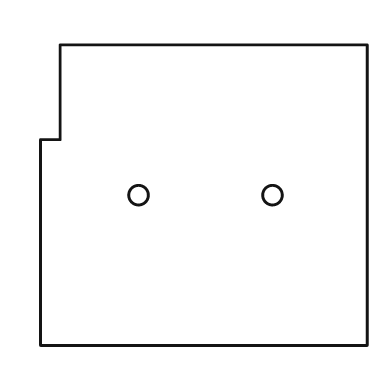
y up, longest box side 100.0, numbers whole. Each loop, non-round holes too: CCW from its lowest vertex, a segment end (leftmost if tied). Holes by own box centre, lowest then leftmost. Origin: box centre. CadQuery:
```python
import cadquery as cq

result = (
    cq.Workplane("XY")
    .moveTo(-50.0, -46.0)
    .lineTo(50.0, -46.0)
    .lineTo(50.0, 46.0)
    .lineTo(-44.0, 46.0)
    .lineTo(-44.0, 17.0)
    .lineTo(-50.0, 17.0)
    .close()
    .moveTo(-20.0, 0.0)
    .circle(3.0)
    .moveTo(21.0, 0.0)
    .circle(3.0)
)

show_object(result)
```